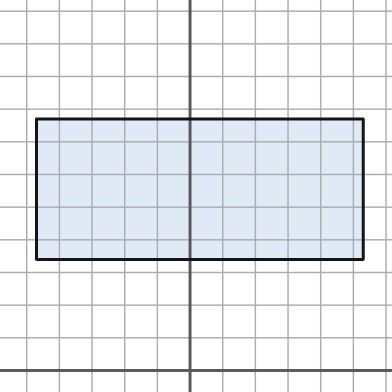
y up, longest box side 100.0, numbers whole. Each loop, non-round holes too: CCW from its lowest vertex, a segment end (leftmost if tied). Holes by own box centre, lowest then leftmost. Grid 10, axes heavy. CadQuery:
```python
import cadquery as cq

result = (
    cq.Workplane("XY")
    .moveTo(-47.0, 34.0)
    .lineTo(53.0, 34.0)
    .lineTo(53.0, 77.0)
    .lineTo(-47.0, 77.0)
    .close()
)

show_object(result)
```